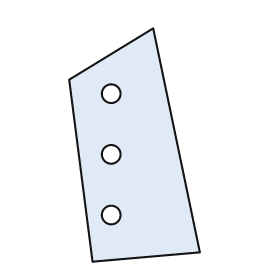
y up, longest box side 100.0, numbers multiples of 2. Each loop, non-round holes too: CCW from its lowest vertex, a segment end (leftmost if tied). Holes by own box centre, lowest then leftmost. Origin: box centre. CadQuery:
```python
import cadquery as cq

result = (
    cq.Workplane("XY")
    .moveTo(-18.0, -50.0)
    .lineTo(28.0, -46.0)
    .lineTo(8.0, 50.0)
    .lineTo(-28.0, 28.0)
    .close()
    .moveTo(-10.0, -30.0)
    .circle(4.0)
    .moveTo(-10.0, -4.0)
    .circle(4.0)
    .moveTo(-10.0, 22.0)
    .circle(4.0)
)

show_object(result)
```